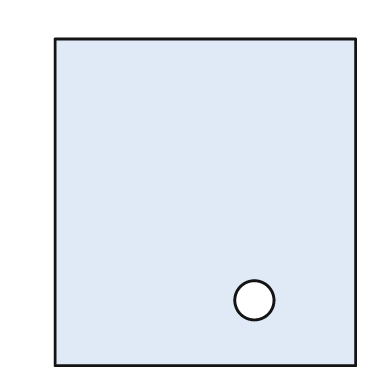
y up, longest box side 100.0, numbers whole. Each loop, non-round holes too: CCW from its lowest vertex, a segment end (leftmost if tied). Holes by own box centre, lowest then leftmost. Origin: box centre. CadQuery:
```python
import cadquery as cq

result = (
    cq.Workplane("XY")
    .moveTo(-46.0, -50.0)
    .lineTo(46.0, -50.0)
    .lineTo(46.0, 50.0)
    .lineTo(-46.0, 50.0)
    .close()
    .moveTo(15.0, -30.0)
    .circle(6.0)
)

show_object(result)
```